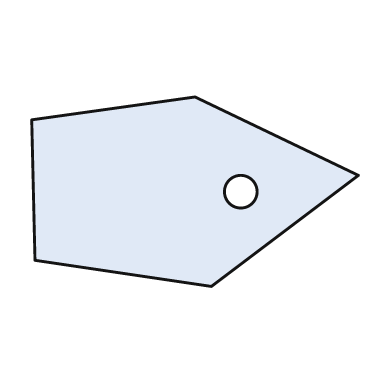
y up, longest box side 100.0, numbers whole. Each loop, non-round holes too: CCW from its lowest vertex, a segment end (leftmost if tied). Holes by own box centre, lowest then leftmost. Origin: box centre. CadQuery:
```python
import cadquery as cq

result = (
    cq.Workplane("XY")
    .moveTo(5.0, -29.0)
    .lineTo(50.0, 5.0)
    .lineTo(0.0, 29.0)
    .lineTo(-50.0, 22.0)
    .lineTo(-49.0, -21.0)
    .close()
    .moveTo(14.0, 0.0)
    .circle(5.0)
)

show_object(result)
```